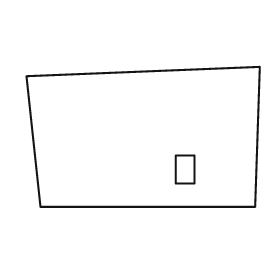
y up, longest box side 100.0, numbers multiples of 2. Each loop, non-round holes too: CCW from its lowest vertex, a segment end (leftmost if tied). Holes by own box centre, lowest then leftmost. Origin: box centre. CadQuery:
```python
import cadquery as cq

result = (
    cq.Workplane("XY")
    .moveTo(-44.0, -30.0)
    .lineTo(48.0, -30.0)
    .lineTo(50.0, 30.0)
    .lineTo(-50.0, 26.0)
    .close()
    .moveTo(14.0, -20.0)
    .lineTo(22.0, -20.0)
    .lineTo(22.0, -8.0)
    .lineTo(14.0, -8.0)
    .close()
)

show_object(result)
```